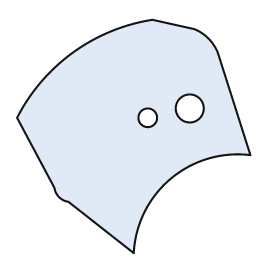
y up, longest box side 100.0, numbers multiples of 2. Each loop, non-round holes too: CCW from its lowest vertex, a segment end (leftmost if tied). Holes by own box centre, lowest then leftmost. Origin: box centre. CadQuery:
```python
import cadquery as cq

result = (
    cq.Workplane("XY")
    .moveTo(0.0, -50.0)
    .threePointArc((16.0, -18.0), (50.0, -8.0))
    .lineTo(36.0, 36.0)
    .threePointArc((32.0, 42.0), (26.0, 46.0))
    .lineTo(8.0, 50.0)
    .threePointArc((-26.0, 36.0), (-50.0, 8.0))
    .lineTo(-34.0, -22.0)
    .threePointArc((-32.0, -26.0), (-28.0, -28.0))
    .close()
    .moveTo(6.0, 8.0)
    .circle(4.0)
    .moveTo(24.0, 12.0)
    .circle(6.0)
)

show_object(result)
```